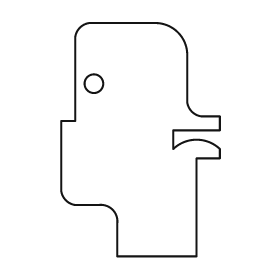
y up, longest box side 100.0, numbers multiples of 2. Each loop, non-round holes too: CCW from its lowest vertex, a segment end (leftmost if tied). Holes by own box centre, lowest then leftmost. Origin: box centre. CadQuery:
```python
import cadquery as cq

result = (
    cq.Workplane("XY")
    .moveTo(-10.0, -50.0)
    .lineTo(24.0, -50.0)
    .lineTo(24.0, -8.0)
    .lineTo(34.0, -8.0)
    .lineTo(34.0, -4.0)
    .threePointArc((24.0, 0.0), (14.0, -4.0))
    .lineTo(14.0, 4.0)
    .lineTo(34.0, 4.0)
    .lineTo(34.0, 10.0)
    .lineTo(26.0, 10.0)
    .threePointArc((22.0, 12.0), (20.0, 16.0))
    .lineTo(20.0, 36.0)
    .threePointArc((16.0, 46.0), (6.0, 50.0))
    .lineTo(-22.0, 50.0)
    .threePointArc((-26.0, 48.0), (-28.0, 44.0))
    .lineTo(-28.0, 8.0)
    .lineTo(-34.0, 8.0)
    .lineTo(-34.0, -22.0)
    .threePointArc((-32.0, -26.0), (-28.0, -28.0))
    .lineTo(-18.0, -28.0)
    .threePointArc((-12.0, -30.0), (-10.0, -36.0))
    .close()
    .moveTo(-20.0, 24.0)
    .circle(4.0)
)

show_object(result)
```